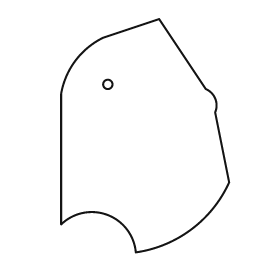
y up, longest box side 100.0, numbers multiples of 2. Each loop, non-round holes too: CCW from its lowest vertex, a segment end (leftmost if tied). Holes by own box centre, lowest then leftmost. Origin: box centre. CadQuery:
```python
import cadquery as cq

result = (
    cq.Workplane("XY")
    .moveTo(-4.0, -50.0)
    .threePointArc((20.0, -40.0), (36.0, -20.0))
    .lineTo(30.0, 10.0)
    .threePointArc((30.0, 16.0), (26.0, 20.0))
    .lineTo(6.0, 50.0)
    .lineTo(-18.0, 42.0)
    .threePointArc((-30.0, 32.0), (-36.0, 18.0))
    .lineTo(-36.0, -38.0)
    .threePointArc((-16.0, -34.0), (-4.0, -50.0))
    .close()
    .moveTo(-16.0, 22.0)
    .circle(2.0)
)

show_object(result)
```